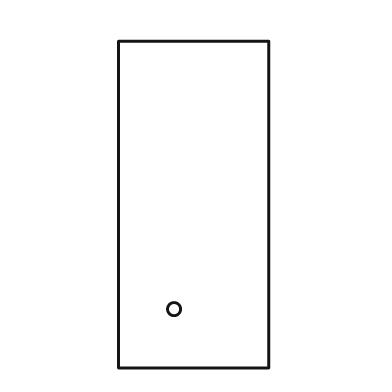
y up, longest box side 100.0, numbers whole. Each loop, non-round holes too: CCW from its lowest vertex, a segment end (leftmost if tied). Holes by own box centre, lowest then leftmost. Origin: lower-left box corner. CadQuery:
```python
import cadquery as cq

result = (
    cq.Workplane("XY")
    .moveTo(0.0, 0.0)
    .lineTo(46.0, 0.0)
    .lineTo(46.0, 100.0)
    .lineTo(0.0, 100.0)
    .close()
    .moveTo(17.0, 18.0)
    .circle(2.0)
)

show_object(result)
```